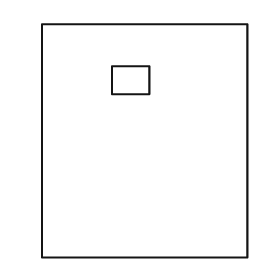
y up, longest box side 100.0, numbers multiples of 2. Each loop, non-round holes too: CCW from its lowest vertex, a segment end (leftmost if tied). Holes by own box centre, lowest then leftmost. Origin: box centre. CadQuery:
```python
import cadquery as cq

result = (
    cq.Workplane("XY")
    .moveTo(-44.0, -50.0)
    .lineTo(44.0, -50.0)
    .lineTo(44.0, 50.0)
    .lineTo(-44.0, 50.0)
    .close()
    .moveTo(-14.0, 20.0)
    .lineTo(2.0, 20.0)
    .lineTo(2.0, 32.0)
    .lineTo(-14.0, 32.0)
    .close()
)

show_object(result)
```